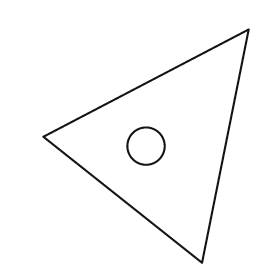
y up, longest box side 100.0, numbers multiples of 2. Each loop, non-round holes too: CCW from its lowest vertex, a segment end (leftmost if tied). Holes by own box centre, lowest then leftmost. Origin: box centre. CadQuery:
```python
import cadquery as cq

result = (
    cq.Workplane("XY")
    .moveTo(24.0, -50.0)
    .lineTo(44.0, 50.0)
    .lineTo(-44.0, 4.0)
    .close()
    .moveTo(0.0, 0.0)
    .circle(8.0)
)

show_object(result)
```